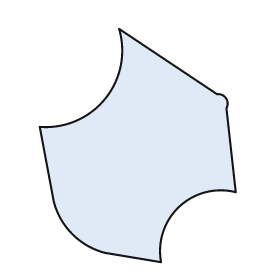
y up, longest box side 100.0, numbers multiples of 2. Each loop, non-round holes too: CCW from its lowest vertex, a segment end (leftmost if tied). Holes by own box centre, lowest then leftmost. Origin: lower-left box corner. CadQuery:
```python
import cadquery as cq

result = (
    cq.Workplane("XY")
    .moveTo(52.0, 0.0)
    .threePointArc((60.0, 24.0), (84.0, 30.0))
    .lineTo(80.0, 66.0)
    .threePointArc((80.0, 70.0), (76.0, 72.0))
    .lineTo(34.0, 100.0)
    .threePointArc((28.0, 70.0), (0.0, 58.0))
    .lineTo(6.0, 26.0)
    .threePointArc((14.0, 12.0), (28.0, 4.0))
    .close()
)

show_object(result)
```